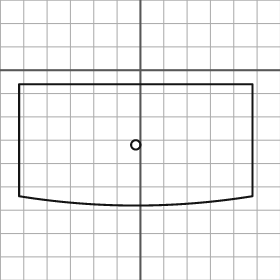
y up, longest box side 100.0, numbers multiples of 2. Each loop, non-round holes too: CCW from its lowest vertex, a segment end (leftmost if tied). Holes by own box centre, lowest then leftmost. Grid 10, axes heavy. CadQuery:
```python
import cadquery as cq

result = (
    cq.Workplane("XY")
    .moveTo(-52.0, -54.0)
    .threePointArc((-2.0, -58.0), (48.0, -54.0))
    .lineTo(48.0, -6.0)
    .lineTo(-52.0, -6.0)
    .close()
    .moveTo(-2.0, -32.0)
    .circle(2.0)
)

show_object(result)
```